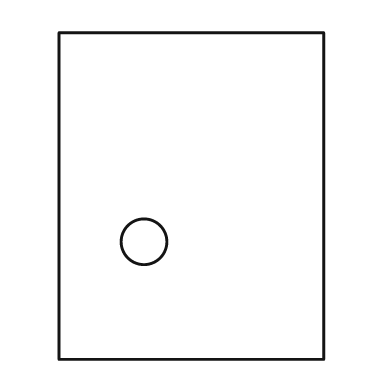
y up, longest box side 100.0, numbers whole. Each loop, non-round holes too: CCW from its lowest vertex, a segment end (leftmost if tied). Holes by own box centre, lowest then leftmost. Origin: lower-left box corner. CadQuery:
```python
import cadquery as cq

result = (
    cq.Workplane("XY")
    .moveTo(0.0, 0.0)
    .lineTo(81.0, 0.0)
    .lineTo(81.0, 100.0)
    .lineTo(0.0, 100.0)
    .close()
    .moveTo(26.0, 36.0)
    .circle(7.0)
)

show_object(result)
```